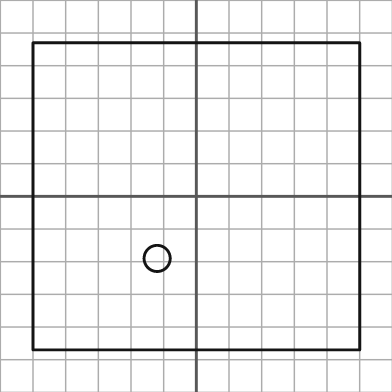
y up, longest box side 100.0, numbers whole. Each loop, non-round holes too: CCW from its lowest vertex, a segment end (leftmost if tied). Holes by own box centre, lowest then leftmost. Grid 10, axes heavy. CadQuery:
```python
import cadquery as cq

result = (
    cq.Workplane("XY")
    .moveTo(-50.0, -47.0)
    .lineTo(50.0, -47.0)
    .lineTo(50.0, 47.0)
    .lineTo(-50.0, 47.0)
    .close()
    .moveTo(-12.0, -19.0)
    .circle(4.0)
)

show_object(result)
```